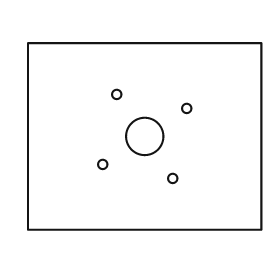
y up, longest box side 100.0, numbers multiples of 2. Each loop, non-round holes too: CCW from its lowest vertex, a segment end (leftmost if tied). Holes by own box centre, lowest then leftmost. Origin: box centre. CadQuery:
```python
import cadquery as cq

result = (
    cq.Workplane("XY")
    .moveTo(-50.0, -40.0)
    .lineTo(50.0, -40.0)
    .lineTo(50.0, 40.0)
    .lineTo(-50.0, 40.0)
    .close()
    .moveTo(12.0, -18.0)
    .circle(2.0)
    .moveTo(-18.0, -12.0)
    .circle(2.0)
    .moveTo(0.0, 0.0)
    .circle(8.0)
    .moveTo(18.0, 12.0)
    .circle(2.0)
    .moveTo(-12.0, 18.0)
    .circle(2.0)
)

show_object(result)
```